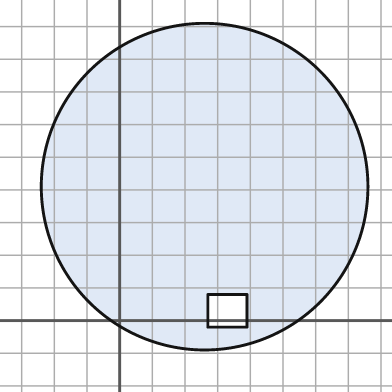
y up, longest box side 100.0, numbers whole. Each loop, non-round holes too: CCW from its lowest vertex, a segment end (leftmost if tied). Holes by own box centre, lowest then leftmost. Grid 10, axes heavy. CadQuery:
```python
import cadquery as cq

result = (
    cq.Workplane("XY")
    .moveTo(26.0, 41.0)
    .circle(50.0)
    .moveTo(27.0, -2.0)
    .lineTo(39.0, -2.0)
    .lineTo(39.0, 8.0)
    .lineTo(27.0, 8.0)
    .close()
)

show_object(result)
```